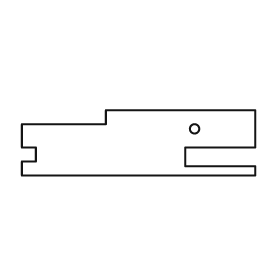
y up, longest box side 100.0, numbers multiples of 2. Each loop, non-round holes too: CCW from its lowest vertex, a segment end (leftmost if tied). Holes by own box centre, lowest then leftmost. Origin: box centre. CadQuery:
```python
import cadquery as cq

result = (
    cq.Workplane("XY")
    .moveTo(-50.0, -14.0)
    .lineTo(50.0, -14.0)
    .lineTo(50.0, -10.0)
    .lineTo(20.0, -10.0)
    .lineTo(20.0, -2.0)
    .lineTo(50.0, -2.0)
    .lineTo(50.0, 14.0)
    .lineTo(-14.0, 14.0)
    .lineTo(-14.0, 8.0)
    .lineTo(-50.0, 8.0)
    .lineTo(-50.0, -2.0)
    .lineTo(-44.0, -2.0)
    .lineTo(-44.0, -8.0)
    .lineTo(-50.0, -8.0)
    .close()
    .moveTo(24.0, 6.0)
    .circle(2.0)
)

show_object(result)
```